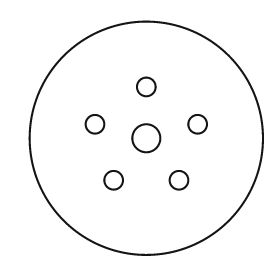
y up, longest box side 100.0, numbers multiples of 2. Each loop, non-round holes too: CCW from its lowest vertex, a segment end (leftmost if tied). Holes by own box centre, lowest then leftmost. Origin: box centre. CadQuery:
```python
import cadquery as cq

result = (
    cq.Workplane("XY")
    .moveTo(0.0, 0.0)
    .circle(50.0)
    .moveTo(-14.0, -18.0)
    .circle(4.0)
    .moveTo(14.0, -18.0)
    .circle(4.0)
    .moveTo(0.0, 0.0)
    .circle(6.0)
    .moveTo(-22.0, 6.0)
    .circle(4.0)
    .moveTo(22.0, 6.0)
    .circle(4.0)
    .moveTo(0.0, 22.0)
    .circle(4.0)
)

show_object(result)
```